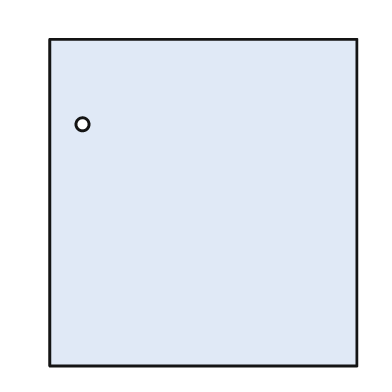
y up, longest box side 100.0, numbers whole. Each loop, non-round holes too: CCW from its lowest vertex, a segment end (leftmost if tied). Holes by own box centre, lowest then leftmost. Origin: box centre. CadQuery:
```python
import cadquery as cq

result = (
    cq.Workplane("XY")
    .moveTo(-47.0, -50.0)
    .lineTo(47.0, -50.0)
    .lineTo(47.0, 50.0)
    .lineTo(-47.0, 50.0)
    .close()
    .moveTo(-37.0, 24.0)
    .circle(2.0)
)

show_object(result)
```